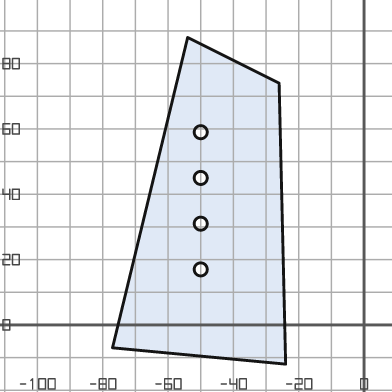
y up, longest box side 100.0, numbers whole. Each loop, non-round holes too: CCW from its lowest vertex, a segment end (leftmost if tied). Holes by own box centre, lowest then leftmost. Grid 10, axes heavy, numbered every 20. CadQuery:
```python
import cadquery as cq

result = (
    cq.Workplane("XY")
    .moveTo(-24.0, -12.0)
    .lineTo(-26.0, 74.0)
    .lineTo(-54.0, 88.0)
    .lineTo(-77.0, -7.0)
    .close()
    .moveTo(-50.0, 17.0)
    .circle(2.0)
    .moveTo(-50.0, 31.0)
    .circle(2.0)
    .moveTo(-50.0, 45.0)
    .circle(2.0)
    .moveTo(-50.0, 59.0)
    .circle(2.0)
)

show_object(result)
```